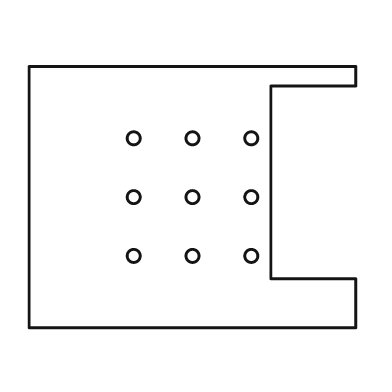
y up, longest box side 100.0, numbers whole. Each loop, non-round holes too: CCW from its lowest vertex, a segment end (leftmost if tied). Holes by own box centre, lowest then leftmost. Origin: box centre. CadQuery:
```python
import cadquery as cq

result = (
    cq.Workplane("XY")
    .moveTo(-50.0, -40.0)
    .lineTo(50.0, -40.0)
    .lineTo(50.0, -25.0)
    .lineTo(24.0, -25.0)
    .lineTo(24.0, 34.0)
    .lineTo(50.0, 34.0)
    .lineTo(50.0, 40.0)
    .lineTo(-50.0, 40.0)
    .close()
    .moveTo(-18.0, -18.0)
    .circle(2.0)
    .moveTo(0.0, -18.0)
    .circle(2.0)
    .moveTo(18.0, -18.0)
    .circle(2.0)
    .moveTo(-18.0, 0.0)
    .circle(2.0)
    .moveTo(0.0, 0.0)
    .circle(2.0)
    .moveTo(18.0, 0.0)
    .circle(2.0)
    .moveTo(-18.0, 18.0)
    .circle(2.0)
    .moveTo(0.0, 18.0)
    .circle(2.0)
    .moveTo(18.0, 18.0)
    .circle(2.0)
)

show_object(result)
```